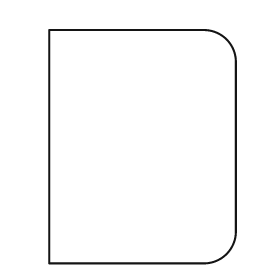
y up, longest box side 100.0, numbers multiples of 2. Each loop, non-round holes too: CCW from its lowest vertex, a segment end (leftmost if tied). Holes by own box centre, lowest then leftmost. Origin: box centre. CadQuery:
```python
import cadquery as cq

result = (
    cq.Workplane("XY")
    .moveTo(-40.0, -50.0)
    .lineTo(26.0, -50.0)
    .threePointArc((36.0, -46.0), (40.0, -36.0))
    .lineTo(40.0, 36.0)
    .threePointArc((36.0, 46.0), (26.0, 50.0))
    .lineTo(-40.0, 50.0)
    .close()
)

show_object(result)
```